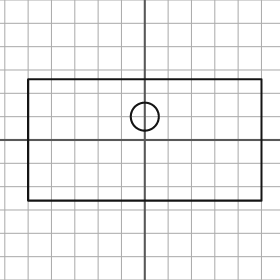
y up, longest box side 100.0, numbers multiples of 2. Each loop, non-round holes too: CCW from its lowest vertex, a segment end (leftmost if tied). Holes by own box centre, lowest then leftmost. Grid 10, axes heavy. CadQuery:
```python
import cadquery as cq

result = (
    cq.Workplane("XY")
    .moveTo(-50.0, -26.0)
    .lineTo(50.0, -26.0)
    .lineTo(50.0, 26.0)
    .lineTo(-50.0, 26.0)
    .close()
    .moveTo(0.0, 10.0)
    .circle(6.0)
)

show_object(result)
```